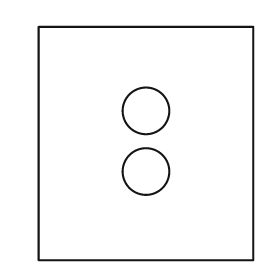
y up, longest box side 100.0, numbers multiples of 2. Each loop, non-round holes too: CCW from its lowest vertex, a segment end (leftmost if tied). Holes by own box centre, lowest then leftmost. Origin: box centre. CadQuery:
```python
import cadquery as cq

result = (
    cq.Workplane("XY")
    .moveTo(-46.0, -50.0)
    .lineTo(46.0, -50.0)
    .lineTo(46.0, 50.0)
    .lineTo(-46.0, 50.0)
    .close()
    .moveTo(0.0, -12.0)
    .circle(10.0)
    .moveTo(0.0, 14.0)
    .circle(10.0)
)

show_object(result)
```